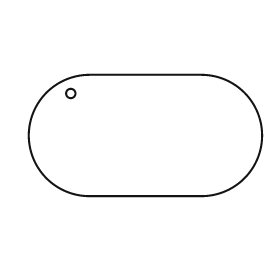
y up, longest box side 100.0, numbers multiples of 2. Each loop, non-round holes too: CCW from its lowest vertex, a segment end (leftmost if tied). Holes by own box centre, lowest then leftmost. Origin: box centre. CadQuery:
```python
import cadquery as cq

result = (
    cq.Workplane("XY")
    .moveTo(-24.0, -26.0)
    .lineTo(24.0, -26.0)
    .threePointArc((50.0, 0.0), (24.0, 26.0))
    .lineTo(-24.0, 26.0)
    .threePointArc((-50.0, 0.0), (-24.0, -26.0))
    .close()
    .moveTo(-32.0, 18.0)
    .circle(2.0)
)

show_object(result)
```